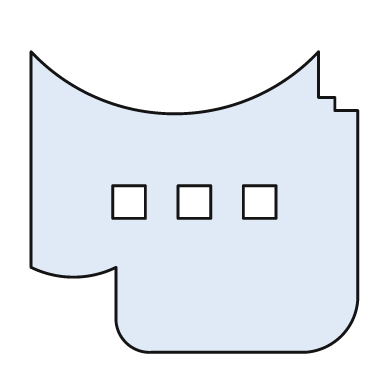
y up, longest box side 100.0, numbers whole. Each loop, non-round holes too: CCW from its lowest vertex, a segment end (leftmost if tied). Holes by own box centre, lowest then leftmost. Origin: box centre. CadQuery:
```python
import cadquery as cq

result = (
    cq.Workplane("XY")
    .moveTo(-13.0, -46.0)
    .lineTo(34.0, -46.0)
    .threePointArc((45.0, -41.0), (50.0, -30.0))
    .lineTo(50.0, 28.0)
    .lineTo(43.0, 28.0)
    .lineTo(43.0, 32.0)
    .lineTo(38.0, 32.0)
    .lineTo(38.0, 46.0)
    .threePointArc((-6.0, 27.0), (-50.0, 46.0))
    .lineTo(-50.0, -20.0)
    .threePointArc((-37.0, -23.0), (-24.0, -20.0))
    .lineTo(-24.0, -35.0)
    .threePointArc((-21.0, -43.0), (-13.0, -46.0))
    .close()
    .moveTo(-25.0, -5.0)
    .lineTo(-15.0, -5.0)
    .lineTo(-15.0, 5.0)
    .lineTo(-25.0, 5.0)
    .close()
    .moveTo(-5.0, -5.0)
    .lineTo(5.0, -5.0)
    .lineTo(5.0, 5.0)
    .lineTo(-5.0, 5.0)
    .close()
    .moveTo(15.0, -5.0)
    .lineTo(25.0, -5.0)
    .lineTo(25.0, 5.0)
    .lineTo(15.0, 5.0)
    .close()
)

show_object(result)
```